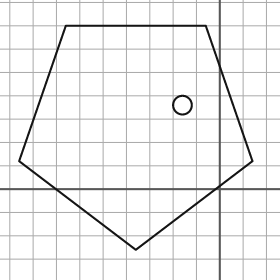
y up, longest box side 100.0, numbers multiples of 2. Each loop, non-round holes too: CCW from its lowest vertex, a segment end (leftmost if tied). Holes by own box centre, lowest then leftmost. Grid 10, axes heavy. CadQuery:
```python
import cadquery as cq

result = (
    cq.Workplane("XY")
    .moveTo(-36.0, -26.0)
    .lineTo(14.0, 12.0)
    .lineTo(-6.0, 70.0)
    .lineTo(-66.0, 70.0)
    .lineTo(-86.0, 12.0)
    .close()
    .moveTo(-16.0, 36.0)
    .circle(4.0)
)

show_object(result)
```